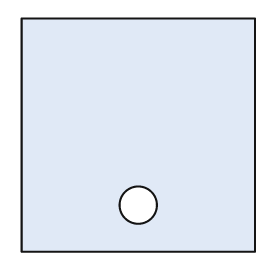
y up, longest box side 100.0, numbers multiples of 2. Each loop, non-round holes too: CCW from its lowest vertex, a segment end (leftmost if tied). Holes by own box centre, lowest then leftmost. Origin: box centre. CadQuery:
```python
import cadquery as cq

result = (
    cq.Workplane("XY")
    .moveTo(-50.0, -50.0)
    .lineTo(50.0, -50.0)
    .lineTo(50.0, 50.0)
    .lineTo(-50.0, 50.0)
    .close()
    .moveTo(0.0, -30.0)
    .circle(8.0)
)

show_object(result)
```